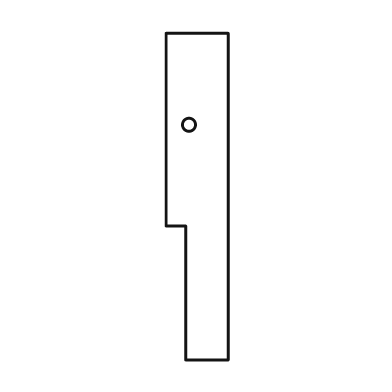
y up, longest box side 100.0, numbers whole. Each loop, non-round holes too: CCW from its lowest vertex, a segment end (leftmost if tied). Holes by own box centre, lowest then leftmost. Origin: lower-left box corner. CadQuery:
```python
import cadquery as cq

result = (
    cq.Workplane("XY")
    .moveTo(6.0, 0.0)
    .lineTo(19.0, 0.0)
    .lineTo(19.0, 100.0)
    .lineTo(0.0, 100.0)
    .lineTo(0.0, 41.0)
    .lineTo(6.0, 41.0)
    .close()
    .moveTo(7.0, 72.0)
    .circle(2.0)
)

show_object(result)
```